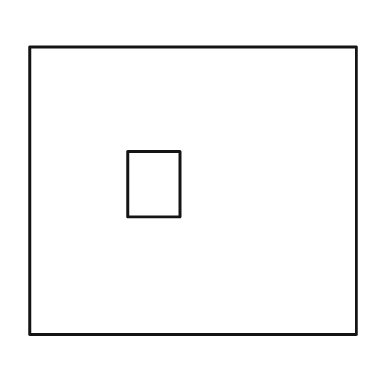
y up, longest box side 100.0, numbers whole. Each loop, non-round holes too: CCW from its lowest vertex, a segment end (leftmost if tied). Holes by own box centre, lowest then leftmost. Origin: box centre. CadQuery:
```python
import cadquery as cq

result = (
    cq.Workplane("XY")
    .moveTo(-50.0, -44.0)
    .lineTo(50.0, -44.0)
    .lineTo(50.0, 44.0)
    .lineTo(-50.0, 44.0)
    .close()
    .moveTo(-20.0, -8.0)
    .lineTo(-4.0, -8.0)
    .lineTo(-4.0, 12.0)
    .lineTo(-20.0, 12.0)
    .close()
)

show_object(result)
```